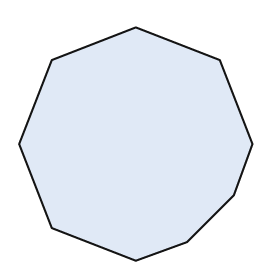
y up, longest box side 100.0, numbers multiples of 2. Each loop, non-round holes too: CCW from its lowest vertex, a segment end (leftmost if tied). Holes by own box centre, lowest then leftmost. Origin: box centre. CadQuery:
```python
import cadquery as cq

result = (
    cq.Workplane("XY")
    .moveTo(0.0, -50.0)
    .lineTo(22.0, -42.0)
    .lineTo(42.0, -22.0)
    .lineTo(50.0, 0.0)
    .lineTo(36.0, 36.0)
    .lineTo(0.0, 50.0)
    .lineTo(-36.0, 36.0)
    .lineTo(-50.0, 0.0)
    .lineTo(-36.0, -36.0)
    .close()
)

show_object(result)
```